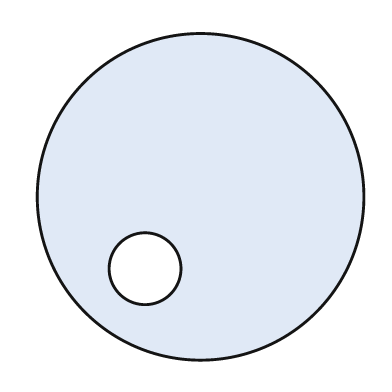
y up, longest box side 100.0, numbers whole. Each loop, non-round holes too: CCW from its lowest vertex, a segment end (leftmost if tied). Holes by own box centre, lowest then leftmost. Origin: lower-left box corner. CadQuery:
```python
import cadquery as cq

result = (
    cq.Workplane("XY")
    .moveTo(50.0, 50.0)
    .circle(50.0)
    .moveTo(33.0, 28.0)
    .circle(11.0)
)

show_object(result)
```